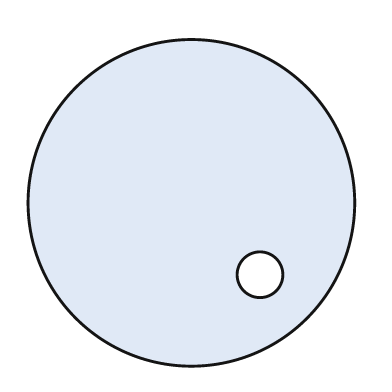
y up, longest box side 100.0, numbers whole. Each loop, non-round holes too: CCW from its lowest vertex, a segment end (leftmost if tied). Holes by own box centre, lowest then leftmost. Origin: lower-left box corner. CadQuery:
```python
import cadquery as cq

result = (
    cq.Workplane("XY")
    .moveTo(50.0, 50.0)
    .circle(50.0)
    .moveTo(71.0, 28.0)
    .circle(7.0)
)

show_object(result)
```